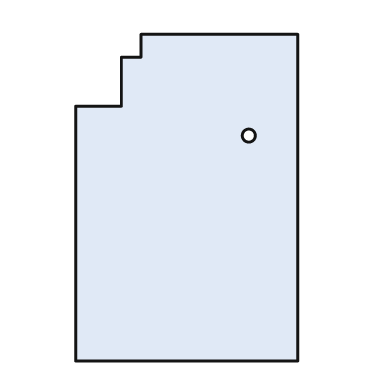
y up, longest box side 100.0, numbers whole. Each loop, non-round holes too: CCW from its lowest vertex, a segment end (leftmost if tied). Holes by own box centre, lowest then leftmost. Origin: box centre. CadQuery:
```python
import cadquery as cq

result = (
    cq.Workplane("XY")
    .moveTo(-34.0, -50.0)
    .lineTo(34.0, -50.0)
    .lineTo(34.0, 50.0)
    .lineTo(-14.0, 50.0)
    .lineTo(-14.0, 43.0)
    .lineTo(-20.0, 43.0)
    .lineTo(-20.0, 28.0)
    .lineTo(-34.0, 28.0)
    .close()
    .moveTo(19.0, 19.0)
    .circle(2.0)
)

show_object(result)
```